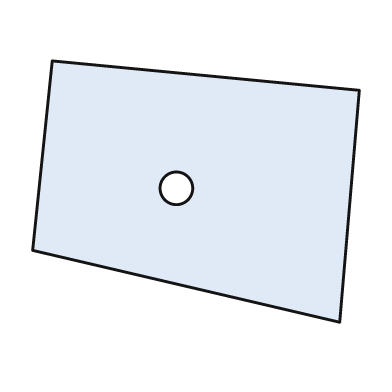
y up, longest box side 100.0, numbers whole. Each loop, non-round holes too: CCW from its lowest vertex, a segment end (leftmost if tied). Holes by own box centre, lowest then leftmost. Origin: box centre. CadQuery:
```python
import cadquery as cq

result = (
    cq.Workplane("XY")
    .moveTo(44.0, -40.0)
    .lineTo(50.0, 31.0)
    .lineTo(-44.0, 40.0)
    .lineTo(-50.0, -18.0)
    .close()
    .moveTo(-6.0, 1.0)
    .circle(5.0)
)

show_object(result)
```